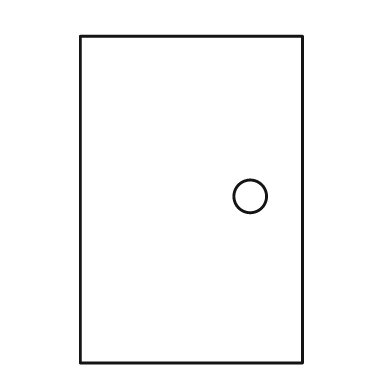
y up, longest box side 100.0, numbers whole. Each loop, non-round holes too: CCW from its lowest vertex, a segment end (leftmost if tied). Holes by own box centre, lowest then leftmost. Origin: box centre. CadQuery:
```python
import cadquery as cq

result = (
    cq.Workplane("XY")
    .moveTo(-34.0, -50.0)
    .lineTo(34.0, -50.0)
    .lineTo(34.0, 50.0)
    .lineTo(-34.0, 50.0)
    .close()
    .moveTo(18.0, 1.0)
    .circle(5.0)
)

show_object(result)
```